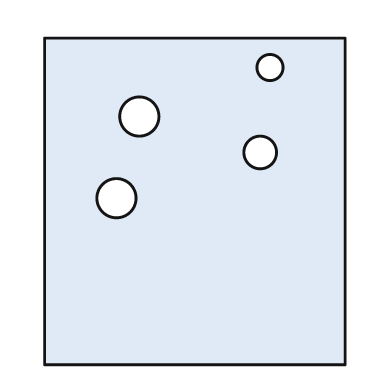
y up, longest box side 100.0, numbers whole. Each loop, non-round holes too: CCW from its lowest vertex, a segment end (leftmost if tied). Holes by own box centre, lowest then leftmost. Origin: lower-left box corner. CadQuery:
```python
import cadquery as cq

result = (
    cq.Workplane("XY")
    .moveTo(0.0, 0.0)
    .lineTo(92.0, 0.0)
    .lineTo(92.0, 100.0)
    .lineTo(0.0, 100.0)
    .close()
    .moveTo(22.0, 51.0)
    .circle(6.0)
    .moveTo(66.0, 65.0)
    .circle(5.0)
    .moveTo(29.0, 76.0)
    .circle(6.0)
    .moveTo(69.0, 91.0)
    .circle(4.0)
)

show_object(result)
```